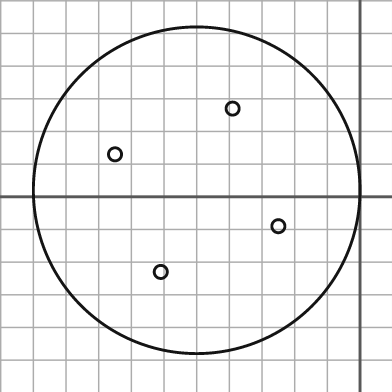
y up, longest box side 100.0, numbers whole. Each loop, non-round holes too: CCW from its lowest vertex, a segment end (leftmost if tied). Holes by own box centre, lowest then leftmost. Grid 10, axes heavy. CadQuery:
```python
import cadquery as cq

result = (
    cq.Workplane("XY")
    .moveTo(-50.0, 2.0)
    .circle(50.0)
    .moveTo(-61.0, -23.0)
    .circle(2.0)
    .moveTo(-25.0, -9.0)
    .circle(2.0)
    .moveTo(-75.0, 13.0)
    .circle(2.0)
    .moveTo(-39.0, 27.0)
    .circle(2.0)
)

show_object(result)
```